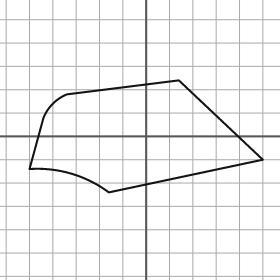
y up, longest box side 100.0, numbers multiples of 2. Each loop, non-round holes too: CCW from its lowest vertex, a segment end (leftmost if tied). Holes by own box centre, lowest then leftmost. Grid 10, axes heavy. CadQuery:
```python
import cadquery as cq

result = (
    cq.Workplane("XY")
    .moveTo(-16.0, -24.0)
    .lineTo(50.0, -10.0)
    .lineTo(14.0, 24.0)
    .lineTo(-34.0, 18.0)
    .threePointArc((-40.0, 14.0), (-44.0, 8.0))
    .lineTo(-50.0, -14.0)
    .threePointArc((-32.0, -16.0), (-16.0, -24.0))
    .close()
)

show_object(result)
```